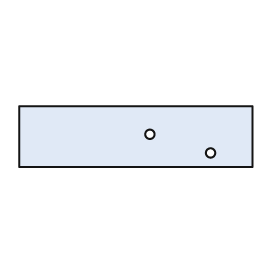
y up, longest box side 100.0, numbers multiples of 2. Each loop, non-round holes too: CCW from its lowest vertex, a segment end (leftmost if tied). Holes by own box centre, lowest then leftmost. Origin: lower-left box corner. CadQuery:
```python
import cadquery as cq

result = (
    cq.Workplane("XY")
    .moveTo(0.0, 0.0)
    .lineTo(100.0, 0.0)
    .lineTo(100.0, 26.0)
    .lineTo(0.0, 26.0)
    .close()
    .moveTo(82.0, 6.0)
    .circle(2.0)
    .moveTo(56.0, 14.0)
    .circle(2.0)
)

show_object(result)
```